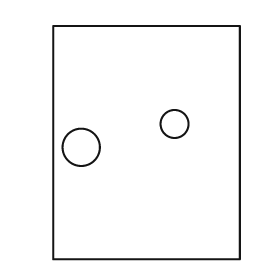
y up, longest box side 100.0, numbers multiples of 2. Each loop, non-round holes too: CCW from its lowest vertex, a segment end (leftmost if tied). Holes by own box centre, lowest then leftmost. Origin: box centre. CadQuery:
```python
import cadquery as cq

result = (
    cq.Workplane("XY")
    .moveTo(-40.0, -50.0)
    .lineTo(40.0, -50.0)
    .lineTo(40.0, 50.0)
    .lineTo(-40.0, 50.0)
    .close()
    .moveTo(-28.0, -2.0)
    .circle(8.0)
    .moveTo(12.0, 8.0)
    .circle(6.0)
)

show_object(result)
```